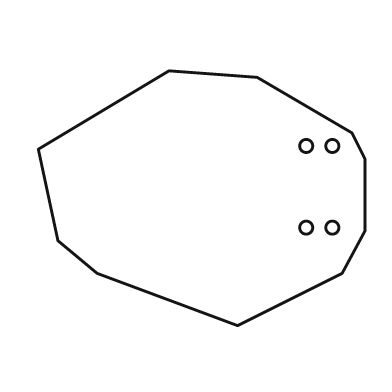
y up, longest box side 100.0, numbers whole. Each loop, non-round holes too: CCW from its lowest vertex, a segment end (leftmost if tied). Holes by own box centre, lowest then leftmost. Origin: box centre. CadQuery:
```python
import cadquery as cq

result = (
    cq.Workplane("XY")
    .moveTo(11.0, -39.0)
    .lineTo(43.0, -23.0)
    .lineTo(50.0, -10.0)
    .lineTo(50.0, 12.0)
    .lineTo(46.0, 20.0)
    .lineTo(17.0, 37.0)
    .lineTo(-10.0, 39.0)
    .lineTo(-50.0, 15.0)
    .lineTo(-44.0, -13.0)
    .lineTo(-32.0, -23.0)
    .close()
    .moveTo(32.0, -9.0)
    .circle(2.0)
    .moveTo(40.0, -9.0)
    .circle(2.0)
    .moveTo(32.0, 16.0)
    .circle(2.0)
    .moveTo(40.0, 16.0)
    .circle(2.0)
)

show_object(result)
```